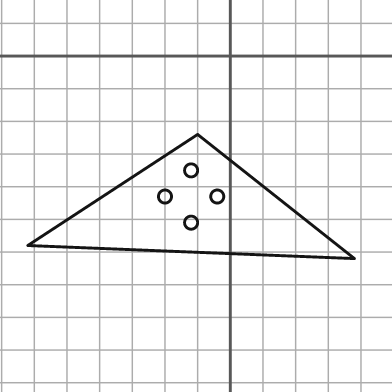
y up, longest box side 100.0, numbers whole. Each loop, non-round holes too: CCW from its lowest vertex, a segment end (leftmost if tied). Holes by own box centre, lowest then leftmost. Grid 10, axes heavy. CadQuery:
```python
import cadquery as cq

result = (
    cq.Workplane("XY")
    .moveTo(38.0, -62.0)
    .lineTo(-10.0, -24.0)
    .lineTo(-62.0, -58.0)
    .close()
    .moveTo(-12.0, -51.0)
    .circle(2.0)
    .moveTo(-20.0, -43.0)
    .circle(2.0)
    .moveTo(-4.0, -43.0)
    .circle(2.0)
    .moveTo(-12.0, -35.0)
    .circle(2.0)
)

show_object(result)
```